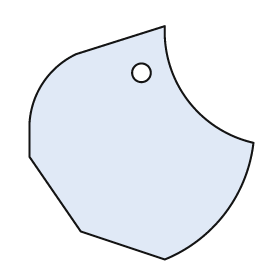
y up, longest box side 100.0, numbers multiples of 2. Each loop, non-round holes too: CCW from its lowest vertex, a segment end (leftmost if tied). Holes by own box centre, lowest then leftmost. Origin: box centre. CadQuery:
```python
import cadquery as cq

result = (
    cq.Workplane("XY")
    .moveTo(10.0, -50.0)
    .threePointArc((36.0, -30.0), (48.0, 0.0))
    .threePointArc((20.0, 18.0), (10.0, 50.0))
    .lineTo(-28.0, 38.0)
    .threePointArc((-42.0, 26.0), (-48.0, 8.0))
    .lineTo(-48.0, -6.0)
    .lineTo(-26.0, -38.0)
    .close()
    .moveTo(0.0, 30.0)
    .circle(4.0)
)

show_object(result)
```